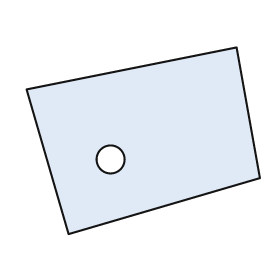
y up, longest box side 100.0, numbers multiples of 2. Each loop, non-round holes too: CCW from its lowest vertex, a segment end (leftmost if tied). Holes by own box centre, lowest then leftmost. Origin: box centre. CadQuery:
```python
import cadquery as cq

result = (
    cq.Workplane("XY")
    .moveTo(-32.0, -40.0)
    .lineTo(50.0, -16.0)
    .lineTo(40.0, 40.0)
    .lineTo(-50.0, 22.0)
    .close()
    .moveTo(-14.0, -8.0)
    .circle(6.0)
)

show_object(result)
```